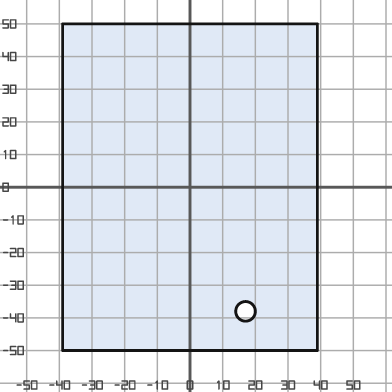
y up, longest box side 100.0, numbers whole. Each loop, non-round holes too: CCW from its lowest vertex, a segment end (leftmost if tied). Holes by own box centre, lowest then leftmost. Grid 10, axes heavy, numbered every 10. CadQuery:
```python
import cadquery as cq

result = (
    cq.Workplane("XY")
    .moveTo(-39.0, -50.0)
    .lineTo(39.0, -50.0)
    .lineTo(39.0, 50.0)
    .lineTo(-39.0, 50.0)
    .close()
    .moveTo(17.0, -38.0)
    .circle(3.0)
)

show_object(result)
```